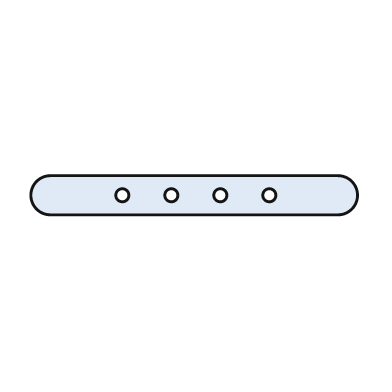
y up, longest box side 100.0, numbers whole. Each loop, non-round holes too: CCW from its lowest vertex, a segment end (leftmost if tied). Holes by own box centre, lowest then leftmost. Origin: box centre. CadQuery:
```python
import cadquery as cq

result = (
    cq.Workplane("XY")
    .moveTo(-44.0, -6.0)
    .lineTo(44.0, -6.0)
    .threePointArc((50.0, 0.0), (44.0, 6.0))
    .lineTo(-44.0, 6.0)
    .threePointArc((-50.0, 0.0), (-44.0, -6.0))
    .close()
    .moveTo(-22.0, 0.0)
    .circle(2.0)
    .moveTo(-7.0, 0.0)
    .circle(2.0)
    .moveTo(8.0, 0.0)
    .circle(2.0)
    .moveTo(23.0, 0.0)
    .circle(2.0)
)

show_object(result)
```